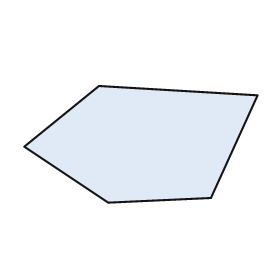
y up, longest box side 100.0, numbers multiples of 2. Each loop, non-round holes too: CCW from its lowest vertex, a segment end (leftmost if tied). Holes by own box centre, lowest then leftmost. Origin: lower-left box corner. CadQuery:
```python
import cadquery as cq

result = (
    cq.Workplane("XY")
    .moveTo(36.0, 0.0)
    .lineTo(80.0, 2.0)
    .lineTo(100.0, 46.0)
    .lineTo(32.0, 50.0)
    .lineTo(0.0, 24.0)
    .close()
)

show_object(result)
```